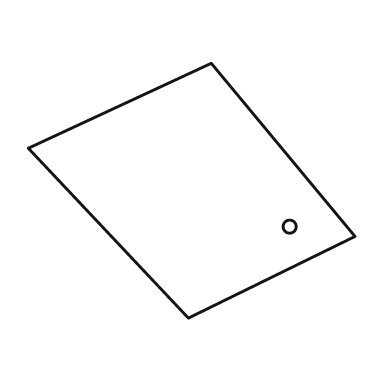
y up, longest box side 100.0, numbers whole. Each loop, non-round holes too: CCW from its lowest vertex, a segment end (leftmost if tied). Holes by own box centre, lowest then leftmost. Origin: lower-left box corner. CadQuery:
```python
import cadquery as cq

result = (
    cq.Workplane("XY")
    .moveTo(49.0, 0.0)
    .lineTo(100.0, 25.0)
    .lineTo(56.0, 78.0)
    .lineTo(0.0, 52.0)
    .close()
    .moveTo(80.0, 28.0)
    .circle(2.0)
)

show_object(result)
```